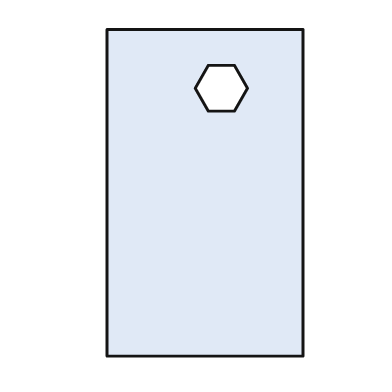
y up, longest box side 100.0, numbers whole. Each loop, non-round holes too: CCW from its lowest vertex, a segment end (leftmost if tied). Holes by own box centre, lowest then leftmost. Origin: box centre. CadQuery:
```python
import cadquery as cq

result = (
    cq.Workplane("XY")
    .moveTo(-30.0, -50.0)
    .lineTo(30.0, -50.0)
    .lineTo(30.0, 50.0)
    .lineTo(-30.0, 50.0)
    .close()
    .moveTo(1.0, 25.0)
    .lineTo(9.0, 25.0)
    .lineTo(13.0, 32.0)
    .lineTo(9.0, 39.0)
    .lineTo(1.0, 39.0)
    .lineTo(-3.0, 32.0)
    .close()
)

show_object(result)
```